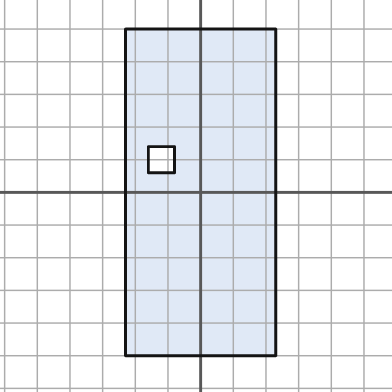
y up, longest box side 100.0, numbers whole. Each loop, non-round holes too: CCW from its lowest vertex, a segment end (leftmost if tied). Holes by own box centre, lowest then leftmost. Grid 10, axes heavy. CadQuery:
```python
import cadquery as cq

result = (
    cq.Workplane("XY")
    .moveTo(-23.0, -50.0)
    .lineTo(23.0, -50.0)
    .lineTo(23.0, 50.0)
    .lineTo(-23.0, 50.0)
    .close()
    .moveTo(-16.0, 6.0)
    .lineTo(-8.0, 6.0)
    .lineTo(-8.0, 14.0)
    .lineTo(-16.0, 14.0)
    .close()
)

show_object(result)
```